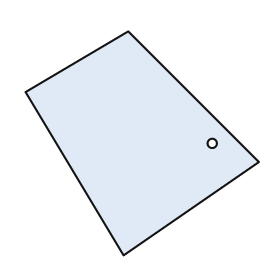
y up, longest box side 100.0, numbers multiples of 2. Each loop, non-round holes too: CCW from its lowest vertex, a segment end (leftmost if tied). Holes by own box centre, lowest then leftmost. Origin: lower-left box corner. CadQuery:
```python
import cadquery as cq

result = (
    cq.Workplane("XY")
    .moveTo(42.0, 0.0)
    .lineTo(100.0, 40.0)
    .lineTo(44.0, 96.0)
    .lineTo(0.0, 70.0)
    .close()
    .moveTo(80.0, 48.0)
    .circle(2.0)
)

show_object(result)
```